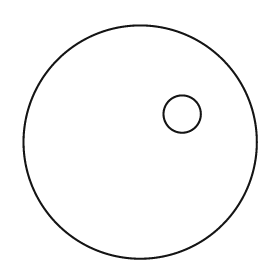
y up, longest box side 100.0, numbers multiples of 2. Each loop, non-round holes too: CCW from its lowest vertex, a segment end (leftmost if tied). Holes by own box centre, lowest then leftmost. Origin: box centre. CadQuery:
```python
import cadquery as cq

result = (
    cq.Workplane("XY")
    .moveTo(0.0, 0.0)
    .circle(50.0)
    .moveTo(18.0, 12.0)
    .circle(8.0)
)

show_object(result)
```